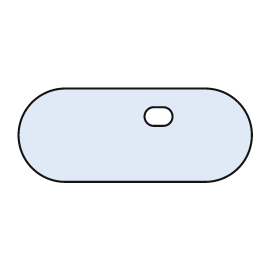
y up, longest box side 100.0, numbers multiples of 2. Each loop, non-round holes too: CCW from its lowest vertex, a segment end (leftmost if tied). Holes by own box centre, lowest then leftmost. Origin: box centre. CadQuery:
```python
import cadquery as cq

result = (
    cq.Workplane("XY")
    .moveTo(-30.0, -20.0)
    .lineTo(30.0, -20.0)
    .threePointArc((50.0, 0.0), (30.0, 20.0))
    .lineTo(-30.0, 20.0)
    .threePointArc((-50.0, 0.0), (-30.0, -20.0))
    .close()
    .moveTo(8.0, 4.0)
    .lineTo(12.0, 4.0)
    .threePointArc((16.0, 8.0), (12.0, 12.0))
    .lineTo(8.0, 12.0)
    .threePointArc((4.0, 8.0), (8.0, 4.0))
    .close()
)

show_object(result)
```